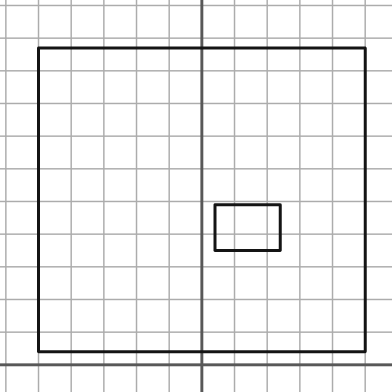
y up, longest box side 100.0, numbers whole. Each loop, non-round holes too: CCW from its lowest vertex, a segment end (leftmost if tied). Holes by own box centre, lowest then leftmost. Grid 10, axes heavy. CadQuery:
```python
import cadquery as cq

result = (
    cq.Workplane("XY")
    .moveTo(-50.0, 4.0)
    .lineTo(50.0, 4.0)
    .lineTo(50.0, 97.0)
    .lineTo(-50.0, 97.0)
    .close()
    .moveTo(4.0, 35.0)
    .lineTo(24.0, 35.0)
    .lineTo(24.0, 49.0)
    .lineTo(4.0, 49.0)
    .close()
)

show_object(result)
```